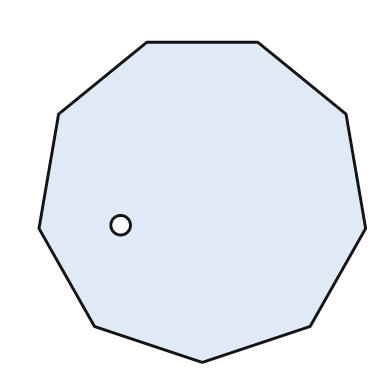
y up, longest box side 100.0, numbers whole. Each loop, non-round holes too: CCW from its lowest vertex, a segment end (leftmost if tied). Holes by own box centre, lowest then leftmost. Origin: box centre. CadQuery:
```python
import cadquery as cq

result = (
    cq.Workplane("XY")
    .moveTo(0.0, -49.0)
    .lineTo(33.0, -38.0)
    .lineTo(50.0, -8.0)
    .lineTo(44.0, 27.0)
    .lineTo(17.0, 49.0)
    .lineTo(-17.0, 49.0)
    .lineTo(-44.0, 27.0)
    .lineTo(-50.0, -8.0)
    .lineTo(-33.0, -38.0)
    .close()
    .moveTo(-25.0, -7.0)
    .circle(3.0)
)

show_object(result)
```